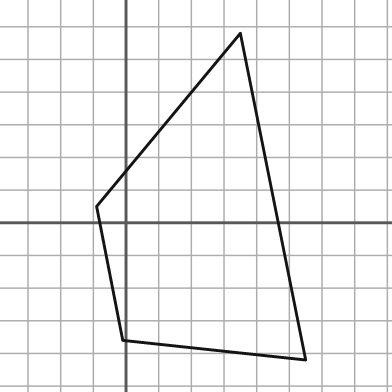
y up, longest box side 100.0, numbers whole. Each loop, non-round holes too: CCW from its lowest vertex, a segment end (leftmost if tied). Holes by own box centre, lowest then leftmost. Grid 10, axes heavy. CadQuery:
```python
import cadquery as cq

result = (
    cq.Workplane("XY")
    .moveTo(55.0, -42.0)
    .lineTo(35.0, 58.0)
    .lineTo(-9.0, 5.0)
    .lineTo(-1.0, -36.0)
    .close()
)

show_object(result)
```